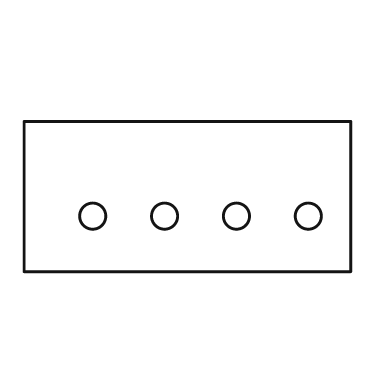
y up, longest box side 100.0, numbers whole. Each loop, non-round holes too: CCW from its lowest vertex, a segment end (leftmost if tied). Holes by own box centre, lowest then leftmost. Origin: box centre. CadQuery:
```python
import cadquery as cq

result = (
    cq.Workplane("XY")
    .moveTo(-50.0, -23.0)
    .lineTo(50.0, -23.0)
    .lineTo(50.0, 23.0)
    .lineTo(-50.0, 23.0)
    .close()
    .moveTo(-29.0, -6.0)
    .circle(4.0)
    .moveTo(-7.0, -6.0)
    .circle(4.0)
    .moveTo(15.0, -6.0)
    .circle(4.0)
    .moveTo(37.0, -6.0)
    .circle(4.0)
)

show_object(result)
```